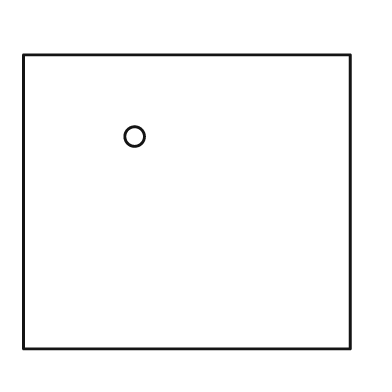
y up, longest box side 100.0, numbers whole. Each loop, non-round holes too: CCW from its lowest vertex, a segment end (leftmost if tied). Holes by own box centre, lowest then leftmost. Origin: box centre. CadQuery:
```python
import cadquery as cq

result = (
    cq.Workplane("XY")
    .moveTo(-50.0, -45.0)
    .lineTo(50.0, -45.0)
    .lineTo(50.0, 45.0)
    .lineTo(-50.0, 45.0)
    .close()
    .moveTo(-16.0, 20.0)
    .circle(3.0)
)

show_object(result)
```